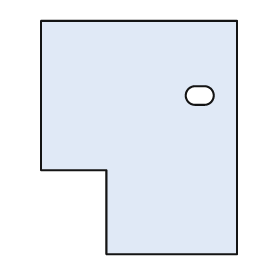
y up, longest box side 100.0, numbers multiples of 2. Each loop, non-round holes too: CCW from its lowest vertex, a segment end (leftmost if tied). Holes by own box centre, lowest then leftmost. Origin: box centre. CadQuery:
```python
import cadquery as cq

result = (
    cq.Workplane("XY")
    .moveTo(-14.0, -50.0)
    .lineTo(42.0, -50.0)
    .lineTo(42.0, 50.0)
    .lineTo(-42.0, 50.0)
    .lineTo(-42.0, -14.0)
    .lineTo(-14.0, -14.0)
    .close()
    .moveTo(24.0, 14.0)
    .lineTo(28.0, 14.0)
    .threePointArc((32.0, 18.0), (28.0, 22.0))
    .lineTo(24.0, 22.0)
    .threePointArc((20.0, 18.0), (24.0, 14.0))
    .close()
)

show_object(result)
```